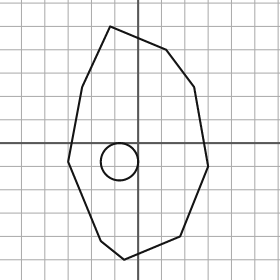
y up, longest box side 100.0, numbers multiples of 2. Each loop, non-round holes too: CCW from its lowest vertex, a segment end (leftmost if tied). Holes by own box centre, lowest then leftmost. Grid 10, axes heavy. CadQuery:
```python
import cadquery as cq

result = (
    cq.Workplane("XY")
    .moveTo(-6.0, -50.0)
    .lineTo(18.0, -40.0)
    .lineTo(30.0, -10.0)
    .lineTo(24.0, 24.0)
    .lineTo(12.0, 40.0)
    .lineTo(-12.0, 50.0)
    .lineTo(-24.0, 24.0)
    .lineTo(-30.0, -8.0)
    .lineTo(-16.0, -42.0)
    .close()
    .moveTo(-8.0, -8.0)
    .circle(8.0)
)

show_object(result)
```